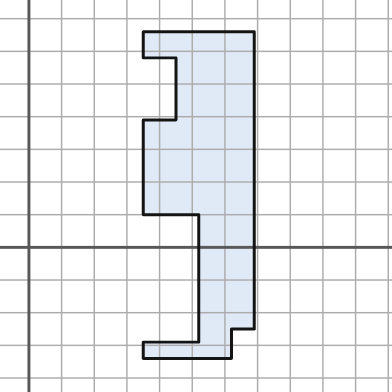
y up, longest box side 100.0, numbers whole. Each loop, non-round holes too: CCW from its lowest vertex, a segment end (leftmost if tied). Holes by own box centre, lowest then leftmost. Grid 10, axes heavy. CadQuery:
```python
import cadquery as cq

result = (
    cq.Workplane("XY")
    .moveTo(35.0, -34.0)
    .lineTo(62.0, -34.0)
    .lineTo(62.0, -25.0)
    .lineTo(69.0, -25.0)
    .lineTo(69.0, 66.0)
    .lineTo(35.0, 66.0)
    .lineTo(35.0, 58.0)
    .lineTo(45.0, 58.0)
    .lineTo(45.0, 39.0)
    .lineTo(35.0, 39.0)
    .lineTo(35.0, 10.0)
    .lineTo(52.0, 10.0)
    .lineTo(52.0, -29.0)
    .lineTo(35.0, -29.0)
    .close()
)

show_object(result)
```